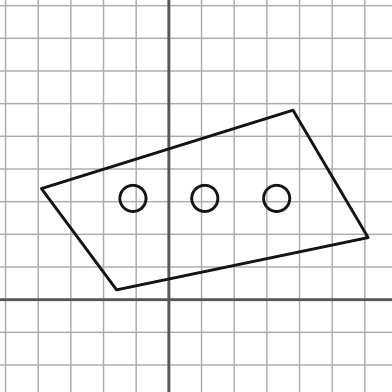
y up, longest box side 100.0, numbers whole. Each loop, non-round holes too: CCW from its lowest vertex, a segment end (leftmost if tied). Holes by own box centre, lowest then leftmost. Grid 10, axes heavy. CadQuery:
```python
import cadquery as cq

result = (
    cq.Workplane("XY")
    .moveTo(-16.0, 3.0)
    .lineTo(61.0, 19.0)
    .lineTo(38.0, 58.0)
    .lineTo(-39.0, 34.0)
    .close()
    .moveTo(-11.0, 31.0)
    .circle(4.0)
    .moveTo(11.0, 31.0)
    .circle(4.0)
    .moveTo(33.0, 31.0)
    .circle(4.0)
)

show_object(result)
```